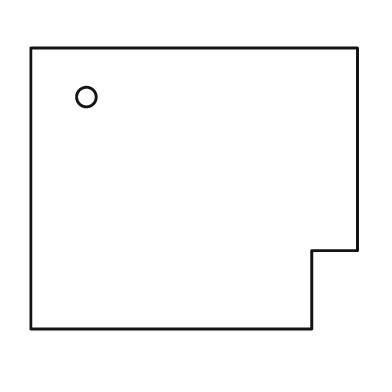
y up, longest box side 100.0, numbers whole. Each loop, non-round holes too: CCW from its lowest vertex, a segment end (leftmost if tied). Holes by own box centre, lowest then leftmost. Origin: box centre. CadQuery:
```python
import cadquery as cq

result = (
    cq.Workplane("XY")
    .moveTo(-50.0, -43.0)
    .lineTo(36.0, -43.0)
    .lineTo(36.0, -19.0)
    .lineTo(50.0, -19.0)
    .lineTo(50.0, 43.0)
    .lineTo(-50.0, 43.0)
    .close()
    .moveTo(-33.0, 28.0)
    .circle(3.0)
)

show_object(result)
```